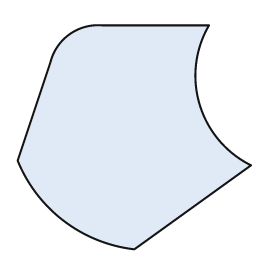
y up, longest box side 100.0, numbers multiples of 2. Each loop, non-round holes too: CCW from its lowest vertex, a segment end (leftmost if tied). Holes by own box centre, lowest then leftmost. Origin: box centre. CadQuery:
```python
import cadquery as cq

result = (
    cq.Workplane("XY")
    .moveTo(0.0, -48.0)
    .lineTo(50.0, -12.0)
    .threePointArc((28.0, 14.0), (32.0, 48.0))
    .lineTo(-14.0, 48.0)
    .threePointArc((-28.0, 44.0), (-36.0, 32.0))
    .lineTo(-50.0, -10.0)
    .threePointArc((-30.0, -36.0), (0.0, -48.0))
    .close()
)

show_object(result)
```